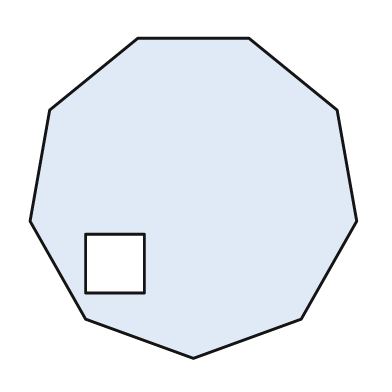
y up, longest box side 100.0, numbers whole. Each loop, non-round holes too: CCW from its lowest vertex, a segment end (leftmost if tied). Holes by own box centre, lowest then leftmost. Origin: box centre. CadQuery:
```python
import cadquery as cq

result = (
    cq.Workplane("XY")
    .moveTo(0.0, -49.0)
    .lineTo(33.0, -37.0)
    .lineTo(50.0, -7.0)
    .lineTo(44.0, 27.0)
    .lineTo(17.0, 49.0)
    .lineTo(-17.0, 49.0)
    .lineTo(-44.0, 27.0)
    .lineTo(-50.0, -7.0)
    .lineTo(-33.0, -37.0)
    .close()
    .moveTo(-33.0, -29.0)
    .lineTo(-15.0, -29.0)
    .lineTo(-15.0, -11.0)
    .lineTo(-33.0, -11.0)
    .close()
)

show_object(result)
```